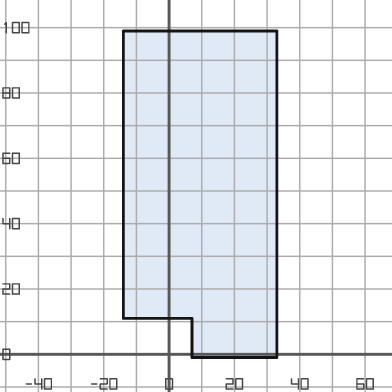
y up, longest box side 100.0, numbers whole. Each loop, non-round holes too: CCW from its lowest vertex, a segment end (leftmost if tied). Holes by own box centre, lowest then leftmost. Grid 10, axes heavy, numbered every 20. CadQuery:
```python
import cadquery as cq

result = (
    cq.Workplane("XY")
    .moveTo(7.0, -1.0)
    .lineTo(33.0, -1.0)
    .lineTo(33.0, 99.0)
    .lineTo(-14.0, 99.0)
    .lineTo(-14.0, 11.0)
    .lineTo(7.0, 11.0)
    .close()
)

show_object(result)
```